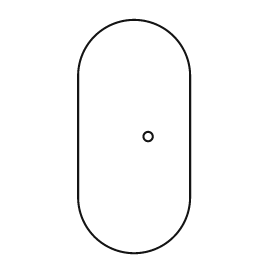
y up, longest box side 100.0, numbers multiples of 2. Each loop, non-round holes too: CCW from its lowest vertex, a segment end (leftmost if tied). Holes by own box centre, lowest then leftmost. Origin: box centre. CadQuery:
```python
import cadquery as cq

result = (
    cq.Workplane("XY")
    .moveTo(-24.0, -26.0)
    .threePointArc((0.0, -50.0), (24.0, -26.0))
    .lineTo(24.0, 26.0)
    .threePointArc((0.0, 50.0), (-24.0, 26.0))
    .close()
    .moveTo(6.0, 0.0)
    .circle(2.0)
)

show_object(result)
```